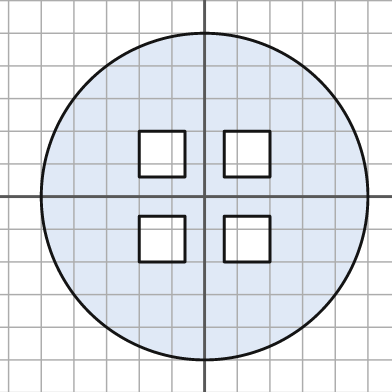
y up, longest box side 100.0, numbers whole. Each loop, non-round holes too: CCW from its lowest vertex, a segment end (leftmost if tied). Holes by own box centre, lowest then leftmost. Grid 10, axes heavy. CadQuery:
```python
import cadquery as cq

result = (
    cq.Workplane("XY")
    .moveTo(0.0, 0.0)
    .circle(50.0)
    .moveTo(-20.0, -20.0)
    .lineTo(-6.0, -20.0)
    .lineTo(-6.0, -6.0)
    .lineTo(-20.0, -6.0)
    .close()
    .moveTo(6.0, -20.0)
    .lineTo(20.0, -20.0)
    .lineTo(20.0, -6.0)
    .lineTo(6.0, -6.0)
    .close()
    .moveTo(-20.0, 6.0)
    .lineTo(-6.0, 6.0)
    .lineTo(-6.0, 20.0)
    .lineTo(-20.0, 20.0)
    .close()
    .moveTo(6.0, 6.0)
    .lineTo(20.0, 6.0)
    .lineTo(20.0, 20.0)
    .lineTo(6.0, 20.0)
    .close()
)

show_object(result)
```